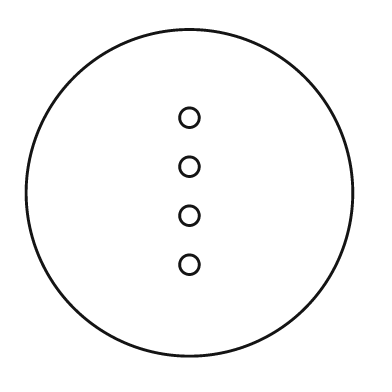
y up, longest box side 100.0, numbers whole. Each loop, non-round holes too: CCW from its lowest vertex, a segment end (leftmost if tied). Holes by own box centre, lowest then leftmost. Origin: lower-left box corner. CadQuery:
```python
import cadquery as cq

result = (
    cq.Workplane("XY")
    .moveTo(50.0, 50.0)
    .circle(50.0)
    .moveTo(50.0, 28.0)
    .circle(3.0)
    .moveTo(50.0, 43.0)
    .circle(3.0)
    .moveTo(50.0, 58.0)
    .circle(3.0)
    .moveTo(50.0, 73.0)
    .circle(3.0)
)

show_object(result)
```